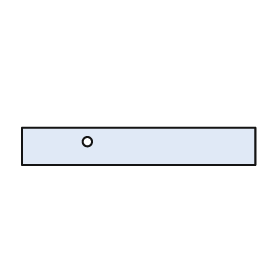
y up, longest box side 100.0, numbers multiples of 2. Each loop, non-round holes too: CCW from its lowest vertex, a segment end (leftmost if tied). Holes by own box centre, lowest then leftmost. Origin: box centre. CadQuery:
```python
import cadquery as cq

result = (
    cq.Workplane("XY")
    .moveTo(-50.0, -8.0)
    .lineTo(50.0, -8.0)
    .lineTo(50.0, 8.0)
    .lineTo(-50.0, 8.0)
    .close()
    .moveTo(-22.0, 2.0)
    .circle(2.0)
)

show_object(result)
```